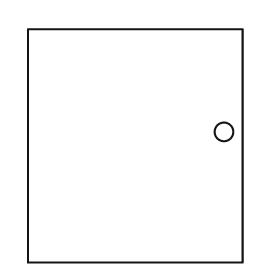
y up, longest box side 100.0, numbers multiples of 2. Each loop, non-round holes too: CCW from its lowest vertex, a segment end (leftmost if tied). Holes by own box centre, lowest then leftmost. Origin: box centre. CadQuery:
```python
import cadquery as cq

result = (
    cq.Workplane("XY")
    .moveTo(-46.0, -50.0)
    .lineTo(46.0, -50.0)
    .lineTo(46.0, 50.0)
    .lineTo(-46.0, 50.0)
    .close()
    .moveTo(38.0, 6.0)
    .circle(4.0)
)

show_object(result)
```